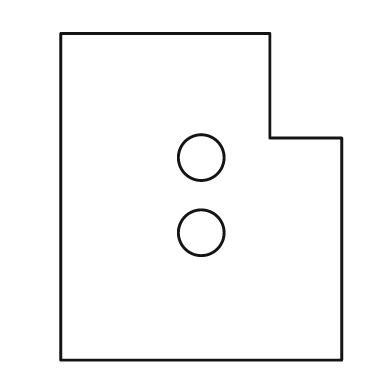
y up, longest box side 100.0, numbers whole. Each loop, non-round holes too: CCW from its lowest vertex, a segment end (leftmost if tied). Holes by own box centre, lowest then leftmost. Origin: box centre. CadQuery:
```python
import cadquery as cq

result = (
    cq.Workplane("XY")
    .moveTo(-43.0, -50.0)
    .lineTo(43.0, -50.0)
    .lineTo(43.0, 18.0)
    .lineTo(21.0, 18.0)
    .lineTo(21.0, 50.0)
    .lineTo(-43.0, 50.0)
    .close()
    .moveTo(0.0, -11.0)
    .circle(7.0)
    .moveTo(0.0, 12.0)
    .circle(7.0)
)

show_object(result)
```